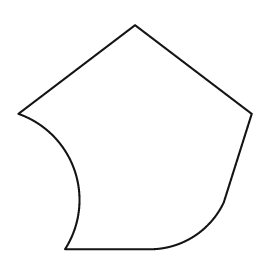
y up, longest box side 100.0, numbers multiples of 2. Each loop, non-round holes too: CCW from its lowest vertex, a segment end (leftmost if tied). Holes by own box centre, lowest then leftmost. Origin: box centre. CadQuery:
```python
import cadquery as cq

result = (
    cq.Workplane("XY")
    .moveTo(-30.0, -48.0)
    .lineTo(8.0, -48.0)
    .threePointArc((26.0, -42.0), (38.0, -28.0))
    .lineTo(50.0, 10.0)
    .lineTo(0.0, 48.0)
    .lineTo(-50.0, 10.0)
    .threePointArc((-26.0, -14.0), (-30.0, -48.0))
    .close()
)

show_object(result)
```